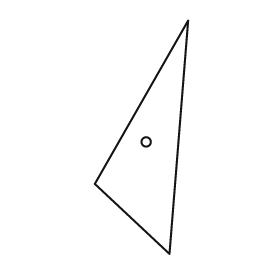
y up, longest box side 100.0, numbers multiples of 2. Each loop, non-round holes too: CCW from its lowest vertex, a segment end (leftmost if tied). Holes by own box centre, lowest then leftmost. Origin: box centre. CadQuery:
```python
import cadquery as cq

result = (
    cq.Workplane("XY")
    .moveTo(12.0, -50.0)
    .lineTo(20.0, 50.0)
    .lineTo(-20.0, -20.0)
    .close()
    .moveTo(2.0, -2.0)
    .circle(2.0)
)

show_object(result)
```